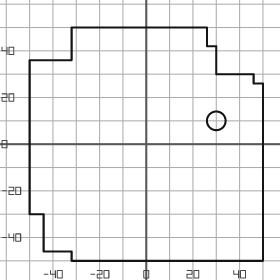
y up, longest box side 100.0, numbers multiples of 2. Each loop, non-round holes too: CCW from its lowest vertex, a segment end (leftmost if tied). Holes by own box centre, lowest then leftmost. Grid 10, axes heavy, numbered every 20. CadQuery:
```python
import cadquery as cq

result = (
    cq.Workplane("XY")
    .moveTo(-32.0, -50.0)
    .lineTo(50.0, -50.0)
    .lineTo(50.0, 26.0)
    .lineTo(46.0, 26.0)
    .lineTo(46.0, 30.0)
    .lineTo(30.0, 30.0)
    .lineTo(30.0, 42.0)
    .lineTo(26.0, 42.0)
    .lineTo(26.0, 50.0)
    .lineTo(-32.0, 50.0)
    .lineTo(-32.0, 36.0)
    .lineTo(-50.0, 36.0)
    .lineTo(-50.0, -30.0)
    .lineTo(-44.0, -30.0)
    .lineTo(-44.0, -46.0)
    .lineTo(-32.0, -46.0)
    .close()
    .moveTo(30.0, 10.0)
    .circle(4.0)
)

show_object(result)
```